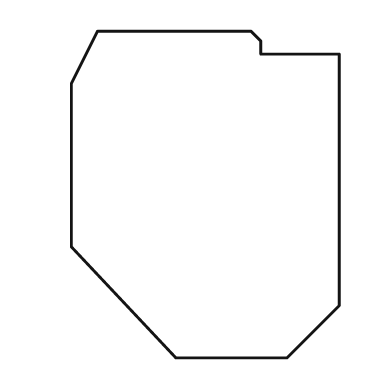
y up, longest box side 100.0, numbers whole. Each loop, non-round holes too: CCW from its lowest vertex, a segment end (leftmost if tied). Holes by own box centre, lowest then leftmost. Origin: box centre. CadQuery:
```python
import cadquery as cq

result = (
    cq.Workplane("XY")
    .moveTo(-9.0, -50.0)
    .lineTo(25.0, -50.0)
    .lineTo(41.0, -34.0)
    .lineTo(41.0, 43.0)
    .lineTo(17.0, 43.0)
    .lineTo(17.0, 47.0)
    .lineTo(14.0, 50.0)
    .lineTo(-33.0, 50.0)
    .lineTo(-41.0, 34.0)
    .lineTo(-41.0, -16.0)
    .close()
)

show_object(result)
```